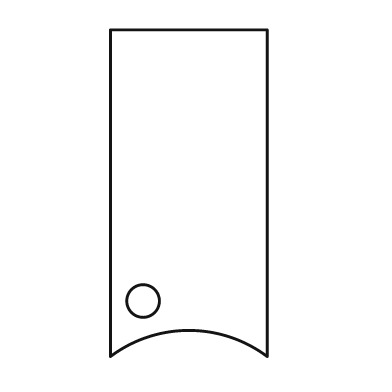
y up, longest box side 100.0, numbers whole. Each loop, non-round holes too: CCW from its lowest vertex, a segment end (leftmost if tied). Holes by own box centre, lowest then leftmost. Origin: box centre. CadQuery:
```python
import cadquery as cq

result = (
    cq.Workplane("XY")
    .moveTo(-24.0, -50.0)
    .threePointArc((0.0, -42.0), (24.0, -50.0))
    .lineTo(24.0, 50.0)
    .lineTo(-24.0, 50.0)
    .close()
    .moveTo(-14.0, -33.0)
    .circle(5.0)
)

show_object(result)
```